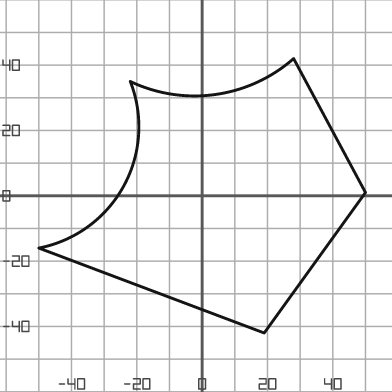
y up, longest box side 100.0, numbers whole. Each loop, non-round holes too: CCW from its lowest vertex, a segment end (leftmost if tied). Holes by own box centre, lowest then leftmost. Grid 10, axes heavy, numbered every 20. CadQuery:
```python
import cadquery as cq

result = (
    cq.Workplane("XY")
    .moveTo(19.0, -42.0)
    .lineTo(50.0, 1.0)
    .lineTo(28.0, 42.0)
    .threePointArc((4.0, 31.0), (-22.0, 35.0))
    .threePointArc((-24.0, 3.0), (-50.0, -16.0))
    .close()
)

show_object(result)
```